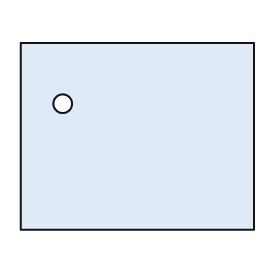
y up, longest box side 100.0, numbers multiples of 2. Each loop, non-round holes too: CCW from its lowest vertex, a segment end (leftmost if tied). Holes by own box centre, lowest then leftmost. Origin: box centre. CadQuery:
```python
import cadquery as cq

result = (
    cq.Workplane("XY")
    .moveTo(-50.0, -40.0)
    .lineTo(50.0, -40.0)
    .lineTo(50.0, 40.0)
    .lineTo(-50.0, 40.0)
    .close()
    .moveTo(-32.0, 14.0)
    .circle(4.0)
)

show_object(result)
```